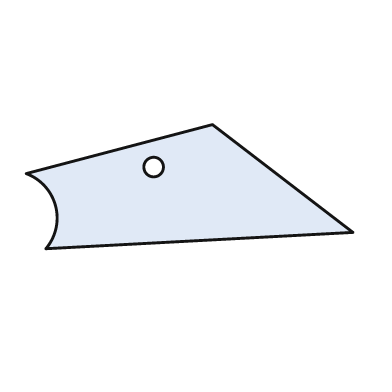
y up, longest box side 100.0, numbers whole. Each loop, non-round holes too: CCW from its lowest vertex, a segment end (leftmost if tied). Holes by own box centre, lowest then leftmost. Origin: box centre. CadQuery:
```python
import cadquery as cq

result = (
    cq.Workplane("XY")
    .moveTo(-44.0, -19.0)
    .lineTo(50.0, -14.0)
    .lineTo(7.0, 19.0)
    .lineTo(-50.0, 4.0)
    .threePointArc((-41.0, -6.0), (-44.0, -19.0))
    .close()
    .moveTo(-11.0, 6.0)
    .circle(3.0)
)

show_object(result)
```